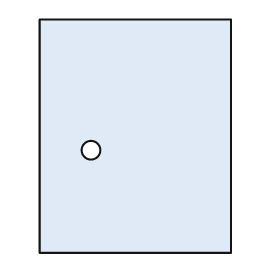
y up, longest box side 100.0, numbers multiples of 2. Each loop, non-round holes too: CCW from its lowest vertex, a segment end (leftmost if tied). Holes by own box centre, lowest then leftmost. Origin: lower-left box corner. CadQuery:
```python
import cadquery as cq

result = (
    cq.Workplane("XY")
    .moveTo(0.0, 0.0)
    .lineTo(82.0, 0.0)
    .lineTo(82.0, 100.0)
    .lineTo(0.0, 100.0)
    .close()
    .moveTo(22.0, 44.0)
    .circle(4.0)
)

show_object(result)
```